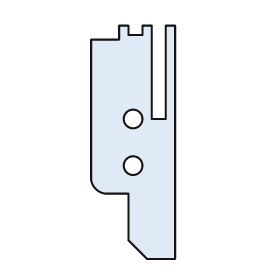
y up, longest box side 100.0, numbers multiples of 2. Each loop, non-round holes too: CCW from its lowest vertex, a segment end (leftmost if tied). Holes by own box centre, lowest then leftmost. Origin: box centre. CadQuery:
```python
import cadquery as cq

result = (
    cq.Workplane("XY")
    .moveTo(6.0, -50.0)
    .lineTo(18.0, -50.0)
    .lineTo(18.0, 50.0)
    .lineTo(14.0, 50.0)
    .lineTo(14.0, 10.0)
    .lineTo(8.0, 10.0)
    .lineTo(8.0, 50.0)
    .lineTo(4.0, 50.0)
    .lineTo(4.0, 46.0)
    .lineTo(-2.0, 46.0)
    .lineTo(-2.0, 50.0)
    .lineTo(-6.0, 50.0)
    .lineTo(-6.0, 44.0)
    .lineTo(-18.0, 44.0)
    .lineTo(-18.0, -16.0)
    .threePointArc((-16.0, -20.0), (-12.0, -22.0))
    .lineTo(-2.0, -22.0)
    .lineTo(-2.0, -42.0)
    .close()
    .moveTo(0.0, -10.0)
    .circle(4.0)
    .moveTo(0.0, 10.0)
    .circle(4.0)
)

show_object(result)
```